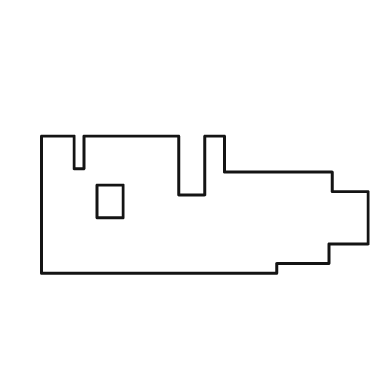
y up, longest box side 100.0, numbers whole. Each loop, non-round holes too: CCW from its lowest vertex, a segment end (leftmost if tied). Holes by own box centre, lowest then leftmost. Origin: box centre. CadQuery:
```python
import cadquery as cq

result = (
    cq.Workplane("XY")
    .moveTo(-50.0, -21.0)
    .lineTo(22.0, -21.0)
    .lineTo(22.0, -18.0)
    .lineTo(38.0, -18.0)
    .lineTo(38.0, -12.0)
    .lineTo(50.0, -12.0)
    .lineTo(50.0, 4.0)
    .lineTo(39.0, 4.0)
    .lineTo(39.0, 10.0)
    .lineTo(6.0, 10.0)
    .lineTo(6.0, 21.0)
    .lineTo(0.0, 21.0)
    .lineTo(0.0, 3.0)
    .lineTo(-8.0, 3.0)
    .lineTo(-8.0, 21.0)
    .lineTo(-37.0, 21.0)
    .lineTo(-37.0, 11.0)
    .lineTo(-40.0, 11.0)
    .lineTo(-40.0, 21.0)
    .lineTo(-50.0, 21.0)
    .close()
    .moveTo(-33.0, -4.0)
    .lineTo(-25.0, -4.0)
    .lineTo(-25.0, 6.0)
    .lineTo(-33.0, 6.0)
    .close()
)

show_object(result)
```